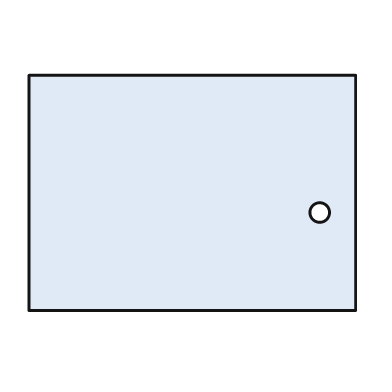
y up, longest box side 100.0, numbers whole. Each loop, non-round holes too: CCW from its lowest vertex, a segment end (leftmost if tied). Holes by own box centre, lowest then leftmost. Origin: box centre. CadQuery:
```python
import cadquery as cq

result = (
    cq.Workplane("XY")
    .moveTo(-50.0, -36.0)
    .lineTo(50.0, -36.0)
    .lineTo(50.0, 36.0)
    .lineTo(-50.0, 36.0)
    .close()
    .moveTo(39.0, -6.0)
    .circle(3.0)
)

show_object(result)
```